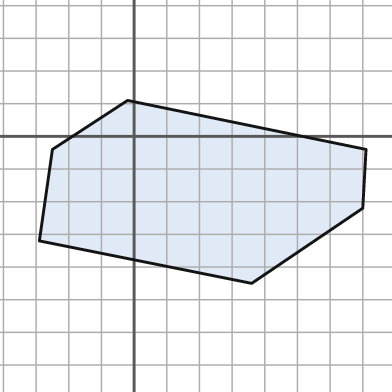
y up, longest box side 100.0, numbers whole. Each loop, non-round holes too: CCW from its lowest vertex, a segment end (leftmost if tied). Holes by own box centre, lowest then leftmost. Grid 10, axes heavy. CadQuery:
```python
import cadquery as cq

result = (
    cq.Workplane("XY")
    .moveTo(36.0, -45.0)
    .lineTo(70.0, -22.0)
    .lineTo(71.0, -4.0)
    .lineTo(-2.0, 11.0)
    .lineTo(-25.0, -4.0)
    .lineTo(-29.0, -32.0)
    .close()
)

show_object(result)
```